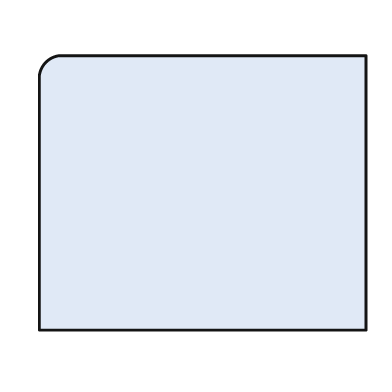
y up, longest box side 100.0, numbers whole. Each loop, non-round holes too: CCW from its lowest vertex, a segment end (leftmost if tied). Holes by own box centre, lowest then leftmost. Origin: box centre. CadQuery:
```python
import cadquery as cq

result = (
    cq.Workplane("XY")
    .moveTo(-50.0, -42.0)
    .lineTo(50.0, -42.0)
    .lineTo(50.0, 42.0)
    .lineTo(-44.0, 42.0)
    .threePointArc((-48.0, 40.0), (-50.0, 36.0))
    .close()
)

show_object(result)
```